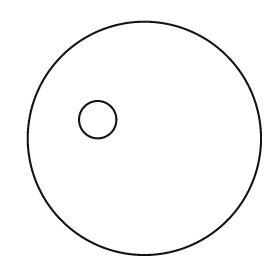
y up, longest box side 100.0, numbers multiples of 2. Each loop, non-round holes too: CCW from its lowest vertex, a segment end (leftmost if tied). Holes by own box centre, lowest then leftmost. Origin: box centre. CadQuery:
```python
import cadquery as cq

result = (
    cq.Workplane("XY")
    .moveTo(0.0, 0.0)
    .circle(50.0)
    .moveTo(-20.0, 8.0)
    .circle(8.0)
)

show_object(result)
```